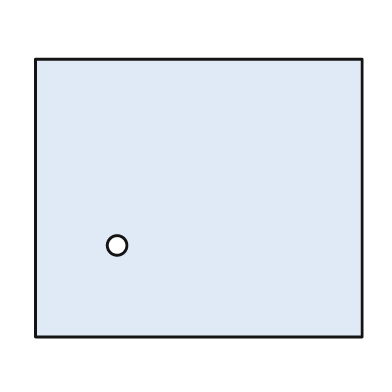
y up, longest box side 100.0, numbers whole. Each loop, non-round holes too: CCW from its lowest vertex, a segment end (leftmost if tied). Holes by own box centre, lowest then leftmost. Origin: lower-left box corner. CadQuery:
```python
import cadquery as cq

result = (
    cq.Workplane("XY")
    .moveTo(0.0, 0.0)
    .lineTo(100.0, 0.0)
    .lineTo(100.0, 85.0)
    .lineTo(0.0, 85.0)
    .close()
    .moveTo(25.0, 28.0)
    .circle(3.0)
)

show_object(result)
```